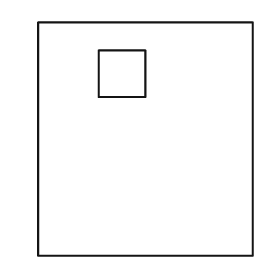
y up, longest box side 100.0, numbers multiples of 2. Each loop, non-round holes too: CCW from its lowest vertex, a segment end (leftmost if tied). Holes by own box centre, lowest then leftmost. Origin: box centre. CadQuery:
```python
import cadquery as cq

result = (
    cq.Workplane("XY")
    .moveTo(-46.0, -50.0)
    .lineTo(46.0, -50.0)
    .lineTo(46.0, 50.0)
    .lineTo(-46.0, 50.0)
    .close()
    .moveTo(-20.0, 18.0)
    .lineTo(0.0, 18.0)
    .lineTo(0.0, 38.0)
    .lineTo(-20.0, 38.0)
    .close()
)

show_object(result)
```